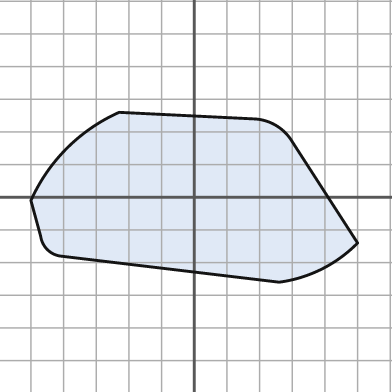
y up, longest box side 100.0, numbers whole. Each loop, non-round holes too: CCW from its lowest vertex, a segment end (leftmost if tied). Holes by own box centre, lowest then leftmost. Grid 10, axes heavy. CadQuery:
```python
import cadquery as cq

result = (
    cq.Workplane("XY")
    .moveTo(26.0, -26.0)
    .threePointArc((39.0, -22.0), (50.0, -14.0))
    .lineTo(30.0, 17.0)
    .threePointArc((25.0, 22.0), (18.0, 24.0))
    .lineTo(-23.0, 26.0)
    .threePointArc((-39.0, 15.0), (-50.0, -1.0))
    .lineTo(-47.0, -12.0)
    .threePointArc((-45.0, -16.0), (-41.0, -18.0))
    .close()
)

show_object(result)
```